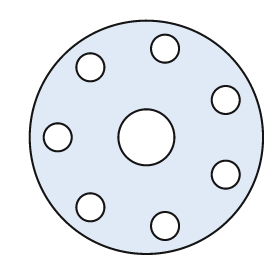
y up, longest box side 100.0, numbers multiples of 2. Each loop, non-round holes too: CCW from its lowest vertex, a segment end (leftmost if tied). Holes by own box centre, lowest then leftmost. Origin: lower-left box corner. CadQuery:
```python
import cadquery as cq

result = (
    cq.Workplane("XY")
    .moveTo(50.0, 50.0)
    .circle(50.0)
    .moveTo(58.0, 12.0)
    .circle(6.0)
    .moveTo(26.0, 20.0)
    .circle(6.0)
    .moveTo(84.0, 34.0)
    .circle(6.0)
    .moveTo(12.0, 50.0)
    .circle(6.0)
    .moveTo(50.0, 50.0)
    .circle(12.0)
    .moveTo(84.0, 66.0)
    .circle(6.0)
    .moveTo(26.0, 80.0)
    .circle(6.0)
    .moveTo(58.0, 88.0)
    .circle(6.0)
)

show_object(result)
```